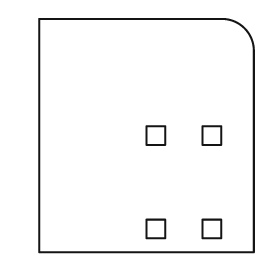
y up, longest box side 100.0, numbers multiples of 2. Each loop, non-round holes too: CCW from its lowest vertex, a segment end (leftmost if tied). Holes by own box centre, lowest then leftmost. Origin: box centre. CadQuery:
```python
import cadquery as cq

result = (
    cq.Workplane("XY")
    .moveTo(-46.0, -50.0)
    .lineTo(46.0, -50.0)
    .lineTo(46.0, 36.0)
    .threePointArc((42.0, 46.0), (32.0, 50.0))
    .lineTo(-46.0, 50.0)
    .close()
    .moveTo(0.0, -44.0)
    .lineTo(8.0, -44.0)
    .lineTo(8.0, -36.0)
    .lineTo(0.0, -36.0)
    .close()
    .moveTo(24.0, -44.0)
    .lineTo(32.0, -44.0)
    .lineTo(32.0, -36.0)
    .lineTo(24.0, -36.0)
    .close()
    .moveTo(0.0, -4.0)
    .lineTo(8.0, -4.0)
    .lineTo(8.0, 4.0)
    .lineTo(0.0, 4.0)
    .close()
    .moveTo(24.0, -4.0)
    .lineTo(32.0, -4.0)
    .lineTo(32.0, 4.0)
    .lineTo(24.0, 4.0)
    .close()
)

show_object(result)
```